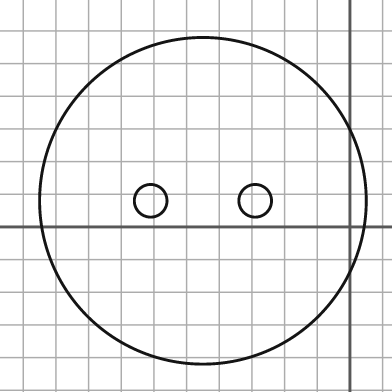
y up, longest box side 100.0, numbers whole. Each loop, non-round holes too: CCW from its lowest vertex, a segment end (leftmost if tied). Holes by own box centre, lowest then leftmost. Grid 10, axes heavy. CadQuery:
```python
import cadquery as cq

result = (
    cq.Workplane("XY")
    .moveTo(-45.0, 8.0)
    .circle(50.0)
    .moveTo(-61.0, 8.0)
    .circle(5.0)
    .moveTo(-29.0, 8.0)
    .circle(5.0)
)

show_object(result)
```